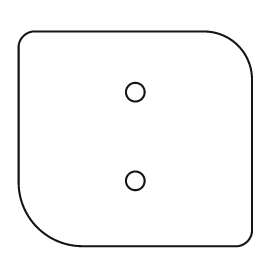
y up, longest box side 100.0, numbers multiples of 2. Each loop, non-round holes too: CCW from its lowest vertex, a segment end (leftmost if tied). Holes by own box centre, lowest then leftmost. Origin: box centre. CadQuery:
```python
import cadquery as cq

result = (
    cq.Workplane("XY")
    .moveTo(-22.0, -46.0)
    .lineTo(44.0, -46.0)
    .threePointArc((48.0, -44.0), (50.0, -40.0))
    .lineTo(50.0, 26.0)
    .threePointArc((44.0, 40.0), (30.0, 46.0))
    .lineTo(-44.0, 46.0)
    .threePointArc((-48.0, 44.0), (-50.0, 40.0))
    .lineTo(-50.0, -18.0)
    .threePointArc((-42.0, -38.0), (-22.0, -46.0))
    .close()
    .moveTo(0.0, -18.0)
    .circle(4.0)
    .moveTo(0.0, 20.0)
    .circle(4.0)
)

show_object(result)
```